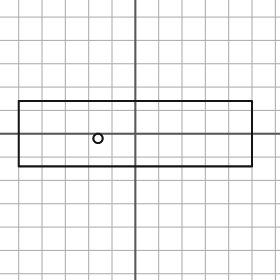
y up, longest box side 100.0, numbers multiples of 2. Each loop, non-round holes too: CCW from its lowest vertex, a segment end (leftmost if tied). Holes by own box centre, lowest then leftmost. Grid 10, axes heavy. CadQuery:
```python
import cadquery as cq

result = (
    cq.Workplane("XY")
    .moveTo(-50.0, -14.0)
    .lineTo(50.0, -14.0)
    .lineTo(50.0, 14.0)
    .lineTo(-50.0, 14.0)
    .close()
    .moveTo(-16.0, -2.0)
    .circle(2.0)
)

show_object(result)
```